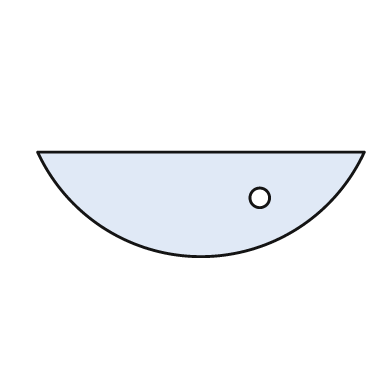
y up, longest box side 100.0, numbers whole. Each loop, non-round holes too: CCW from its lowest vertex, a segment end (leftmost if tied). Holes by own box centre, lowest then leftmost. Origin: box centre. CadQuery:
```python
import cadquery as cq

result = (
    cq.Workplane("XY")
    .moveTo(-50.0, 16.0)
    .threePointArc((0.0, -16.0), (50.0, 16.0))
    .close()
    .moveTo(18.0, 2.0)
    .circle(3.0)
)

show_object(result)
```